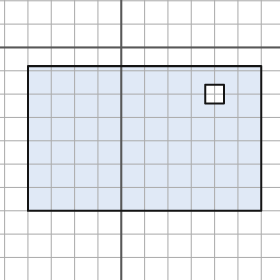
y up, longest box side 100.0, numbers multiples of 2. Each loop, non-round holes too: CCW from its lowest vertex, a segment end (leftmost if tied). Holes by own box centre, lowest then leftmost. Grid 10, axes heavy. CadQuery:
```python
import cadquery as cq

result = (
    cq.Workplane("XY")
    .moveTo(-40.0, -70.0)
    .lineTo(60.0, -70.0)
    .lineTo(60.0, -8.0)
    .lineTo(-40.0, -8.0)
    .close()
    .moveTo(36.0, -24.0)
    .lineTo(44.0, -24.0)
    .lineTo(44.0, -16.0)
    .lineTo(36.0, -16.0)
    .close()
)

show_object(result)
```